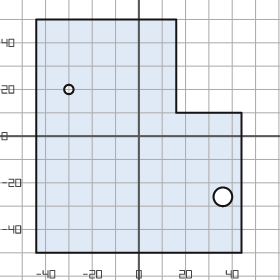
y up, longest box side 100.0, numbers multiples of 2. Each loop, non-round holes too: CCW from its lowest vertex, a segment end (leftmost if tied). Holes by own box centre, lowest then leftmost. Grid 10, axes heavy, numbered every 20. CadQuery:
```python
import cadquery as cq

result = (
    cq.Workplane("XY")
    .moveTo(-44.0, -50.0)
    .lineTo(44.0, -50.0)
    .lineTo(44.0, 10.0)
    .lineTo(16.0, 10.0)
    .lineTo(16.0, 50.0)
    .lineTo(-44.0, 50.0)
    .close()
    .moveTo(36.0, -26.0)
    .circle(4.0)
    .moveTo(-30.0, 20.0)
    .circle(2.0)
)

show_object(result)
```